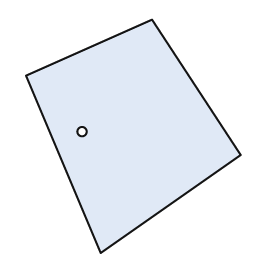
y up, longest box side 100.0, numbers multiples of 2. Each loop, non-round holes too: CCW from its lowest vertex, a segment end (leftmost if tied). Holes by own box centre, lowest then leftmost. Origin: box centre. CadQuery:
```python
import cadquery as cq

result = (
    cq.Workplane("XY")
    .moveTo(-14.0, -50.0)
    .lineTo(46.0, -8.0)
    .lineTo(8.0, 50.0)
    .lineTo(-46.0, 26.0)
    .close()
    .moveTo(-22.0, 2.0)
    .circle(2.0)
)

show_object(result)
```